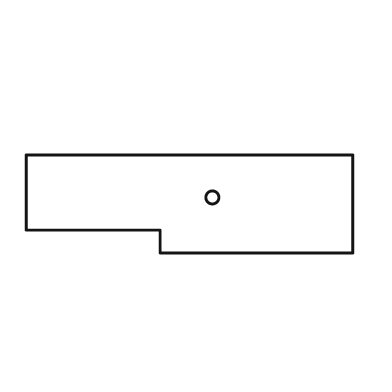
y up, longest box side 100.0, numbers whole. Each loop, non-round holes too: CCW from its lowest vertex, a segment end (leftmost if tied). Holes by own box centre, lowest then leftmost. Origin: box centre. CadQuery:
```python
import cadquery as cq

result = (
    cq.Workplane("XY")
    .moveTo(-9.0, -15.0)
    .lineTo(50.0, -15.0)
    .lineTo(50.0, 15.0)
    .lineTo(-50.0, 15.0)
    .lineTo(-50.0, -8.0)
    .lineTo(-9.0, -8.0)
    .close()
    .moveTo(7.0, 2.0)
    .circle(2.0)
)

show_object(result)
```